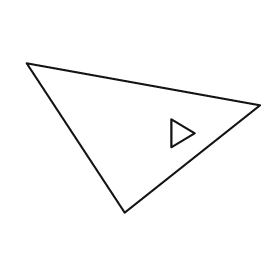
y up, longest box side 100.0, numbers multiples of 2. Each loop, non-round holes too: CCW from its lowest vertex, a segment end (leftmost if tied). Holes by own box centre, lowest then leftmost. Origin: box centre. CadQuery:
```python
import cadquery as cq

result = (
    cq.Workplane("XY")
    .moveTo(-8.0, -32.0)
    .lineTo(50.0, 14.0)
    .lineTo(-50.0, 32.0)
    .close()
    .moveTo(12.0, -4.0)
    .lineTo(22.0, 2.0)
    .lineTo(12.0, 8.0)
    .close()
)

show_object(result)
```